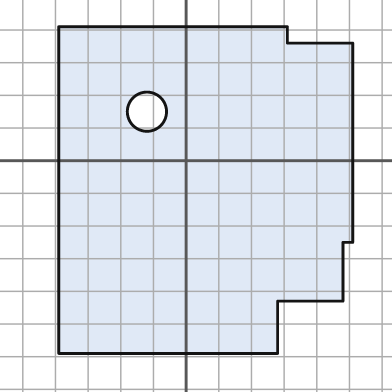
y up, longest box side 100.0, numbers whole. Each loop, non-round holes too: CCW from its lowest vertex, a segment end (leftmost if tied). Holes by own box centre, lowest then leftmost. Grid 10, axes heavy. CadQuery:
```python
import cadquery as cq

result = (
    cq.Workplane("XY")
    .moveTo(-39.0, -59.0)
    .lineTo(28.0, -59.0)
    .lineTo(28.0, -43.0)
    .lineTo(48.0, -43.0)
    .lineTo(48.0, -25.0)
    .lineTo(51.0, -25.0)
    .lineTo(51.0, 36.0)
    .lineTo(31.0, 36.0)
    .lineTo(31.0, 41.0)
    .lineTo(-39.0, 41.0)
    .close()
    .moveTo(-12.0, 15.0)
    .circle(6.0)
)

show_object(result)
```